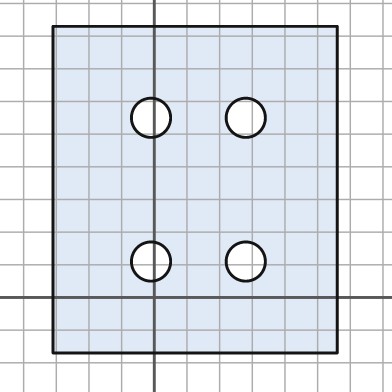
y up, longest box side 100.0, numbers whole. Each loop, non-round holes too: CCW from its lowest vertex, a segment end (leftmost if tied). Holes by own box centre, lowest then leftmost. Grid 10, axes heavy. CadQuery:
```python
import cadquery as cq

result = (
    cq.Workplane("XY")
    .moveTo(-31.0, -17.0)
    .lineTo(56.0, -17.0)
    .lineTo(56.0, 83.0)
    .lineTo(-31.0, 83.0)
    .close()
    .moveTo(-1.0, 11.0)
    .circle(6.0)
    .moveTo(28.0, 11.0)
    .circle(6.0)
    .moveTo(-1.0, 55.0)
    .circle(6.0)
    .moveTo(28.0, 55.0)
    .circle(6.0)
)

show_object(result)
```